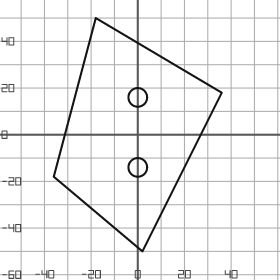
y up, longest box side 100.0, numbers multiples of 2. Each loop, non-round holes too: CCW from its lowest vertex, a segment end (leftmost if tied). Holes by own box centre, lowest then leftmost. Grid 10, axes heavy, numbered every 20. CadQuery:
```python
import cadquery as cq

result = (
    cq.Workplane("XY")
    .moveTo(2.0, -50.0)
    .lineTo(36.0, 18.0)
    .lineTo(-18.0, 50.0)
    .lineTo(-36.0, -18.0)
    .close()
    .moveTo(0.0, -14.0)
    .circle(4.0)
    .moveTo(0.0, 16.0)
    .circle(4.0)
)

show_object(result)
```